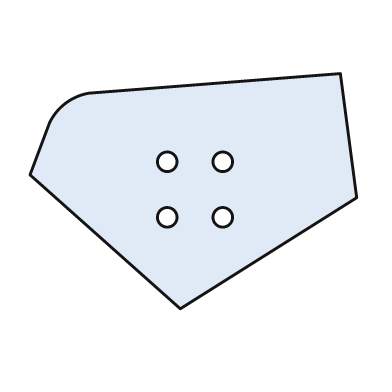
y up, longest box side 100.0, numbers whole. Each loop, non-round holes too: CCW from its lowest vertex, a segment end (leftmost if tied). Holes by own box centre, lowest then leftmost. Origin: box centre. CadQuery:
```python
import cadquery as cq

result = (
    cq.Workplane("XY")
    .moveTo(-4.0, -36.0)
    .lineTo(50.0, -2.0)
    .lineTo(45.0, 36.0)
    .lineTo(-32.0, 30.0)
    .threePointArc((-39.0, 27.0), (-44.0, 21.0))
    .lineTo(-50.0, 5.0)
    .close()
    .moveTo(-8.0, -8.0)
    .circle(3.0)
    .moveTo(9.0, -8.0)
    .circle(3.0)
    .moveTo(-8.0, 9.0)
    .circle(3.0)
    .moveTo(9.0, 9.0)
    .circle(3.0)
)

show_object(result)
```